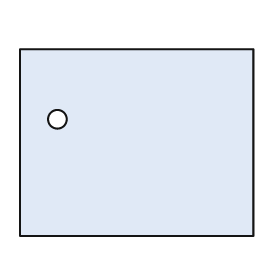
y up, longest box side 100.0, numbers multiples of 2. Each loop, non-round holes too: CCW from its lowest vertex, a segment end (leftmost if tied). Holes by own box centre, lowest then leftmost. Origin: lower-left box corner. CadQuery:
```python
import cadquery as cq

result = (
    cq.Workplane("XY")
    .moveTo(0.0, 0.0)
    .lineTo(100.0, 0.0)
    .lineTo(100.0, 80.0)
    .lineTo(0.0, 80.0)
    .close()
    .moveTo(16.0, 50.0)
    .circle(4.0)
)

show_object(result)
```